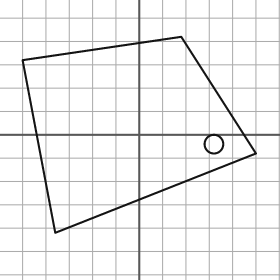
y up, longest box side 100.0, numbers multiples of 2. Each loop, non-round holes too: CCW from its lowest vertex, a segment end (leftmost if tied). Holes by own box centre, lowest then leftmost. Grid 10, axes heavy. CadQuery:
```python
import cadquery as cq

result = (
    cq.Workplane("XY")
    .moveTo(-36.0, -42.0)
    .lineTo(50.0, -8.0)
    .lineTo(18.0, 42.0)
    .lineTo(-50.0, 32.0)
    .close()
    .moveTo(32.0, -4.0)
    .circle(4.0)
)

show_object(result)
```